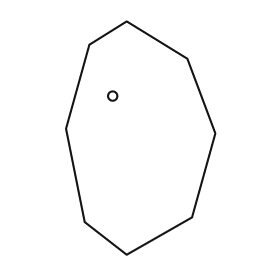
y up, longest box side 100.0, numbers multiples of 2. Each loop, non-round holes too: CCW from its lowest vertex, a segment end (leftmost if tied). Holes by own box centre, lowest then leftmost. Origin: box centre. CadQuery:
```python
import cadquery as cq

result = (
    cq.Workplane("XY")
    .moveTo(-6.0, -50.0)
    .lineTo(22.0, -34.0)
    .lineTo(32.0, 2.0)
    .lineTo(20.0, 34.0)
    .lineTo(-6.0, 50.0)
    .lineTo(-22.0, 40.0)
    .lineTo(-32.0, 4.0)
    .lineTo(-24.0, -36.0)
    .close()
    .moveTo(-12.0, 18.0)
    .circle(2.0)
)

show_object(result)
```